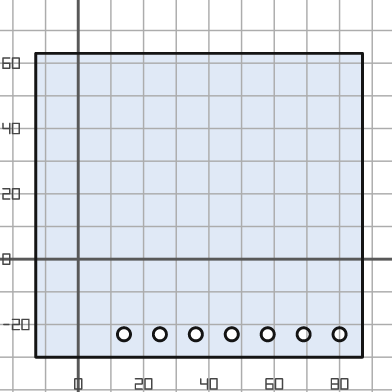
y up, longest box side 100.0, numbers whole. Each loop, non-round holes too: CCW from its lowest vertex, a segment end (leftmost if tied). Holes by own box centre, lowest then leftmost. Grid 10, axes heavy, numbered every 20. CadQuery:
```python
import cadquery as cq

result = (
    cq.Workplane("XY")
    .moveTo(-13.0, -30.0)
    .lineTo(87.0, -30.0)
    .lineTo(87.0, 63.0)
    .lineTo(-13.0, 63.0)
    .close()
    .moveTo(14.0, -23.0)
    .circle(2.0)
    .moveTo(25.0, -23.0)
    .circle(2.0)
    .moveTo(36.0, -23.0)
    .circle(2.0)
    .moveTo(47.0, -23.0)
    .circle(2.0)
    .moveTo(58.0, -23.0)
    .circle(2.0)
    .moveTo(69.0, -23.0)
    .circle(2.0)
    .moveTo(80.0, -23.0)
    .circle(2.0)
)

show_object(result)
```